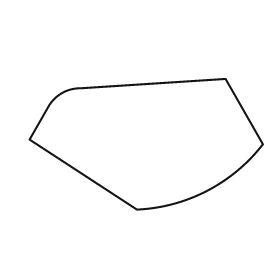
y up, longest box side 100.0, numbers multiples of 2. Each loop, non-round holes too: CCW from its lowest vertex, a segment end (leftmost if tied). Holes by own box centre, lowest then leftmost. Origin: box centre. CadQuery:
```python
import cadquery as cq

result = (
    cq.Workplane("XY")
    .moveTo(-4.0, -28.0)
    .threePointArc((26.0, -20.0), (50.0, 0.0))
    .lineTo(34.0, 28.0)
    .lineTo(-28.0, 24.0)
    .threePointArc((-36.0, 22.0), (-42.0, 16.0))
    .lineTo(-50.0, 2.0)
    .close()
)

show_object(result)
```